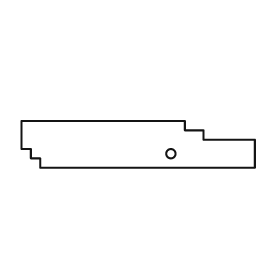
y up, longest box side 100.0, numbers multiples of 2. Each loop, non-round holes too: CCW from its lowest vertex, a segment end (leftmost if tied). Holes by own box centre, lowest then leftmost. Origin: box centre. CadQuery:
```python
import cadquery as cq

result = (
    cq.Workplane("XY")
    .moveTo(-42.0, -10.0)
    .lineTo(50.0, -10.0)
    .lineTo(50.0, 2.0)
    .lineTo(28.0, 2.0)
    .lineTo(28.0, 6.0)
    .lineTo(20.0, 6.0)
    .lineTo(20.0, 10.0)
    .lineTo(-50.0, 10.0)
    .lineTo(-50.0, -2.0)
    .lineTo(-46.0, -2.0)
    .lineTo(-46.0, -6.0)
    .lineTo(-42.0, -6.0)
    .close()
    .moveTo(14.0, -4.0)
    .circle(2.0)
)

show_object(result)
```